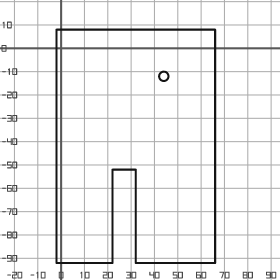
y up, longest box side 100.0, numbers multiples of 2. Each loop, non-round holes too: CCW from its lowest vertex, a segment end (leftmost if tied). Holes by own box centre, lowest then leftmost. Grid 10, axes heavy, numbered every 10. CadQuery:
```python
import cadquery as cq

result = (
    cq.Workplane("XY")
    .moveTo(-2.0, -92.0)
    .lineTo(22.0, -92.0)
    .lineTo(22.0, -52.0)
    .lineTo(32.0, -52.0)
    .lineTo(32.0, -92.0)
    .lineTo(66.0, -92.0)
    .lineTo(66.0, 8.0)
    .lineTo(-2.0, 8.0)
    .close()
    .moveTo(44.0, -12.0)
    .circle(2.0)
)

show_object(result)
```